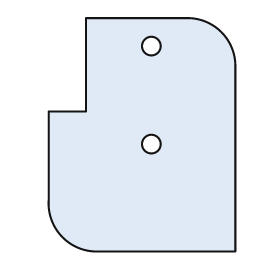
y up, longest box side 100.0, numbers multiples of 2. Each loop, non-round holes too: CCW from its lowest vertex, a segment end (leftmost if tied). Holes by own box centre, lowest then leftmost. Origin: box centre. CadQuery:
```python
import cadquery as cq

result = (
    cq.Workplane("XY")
    .moveTo(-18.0, -50.0)
    .lineTo(40.0, -50.0)
    .lineTo(40.0, 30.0)
    .threePointArc((34.0, 44.0), (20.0, 50.0))
    .lineTo(-24.0, 50.0)
    .lineTo(-24.0, 10.0)
    .lineTo(-40.0, 10.0)
    .lineTo(-40.0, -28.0)
    .threePointArc((-34.0, -44.0), (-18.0, -50.0))
    .close()
    .moveTo(4.0, -4.0)
    .circle(4.0)
    .moveTo(4.0, 38.0)
    .circle(4.0)
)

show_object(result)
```